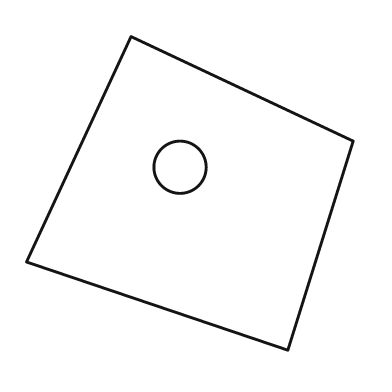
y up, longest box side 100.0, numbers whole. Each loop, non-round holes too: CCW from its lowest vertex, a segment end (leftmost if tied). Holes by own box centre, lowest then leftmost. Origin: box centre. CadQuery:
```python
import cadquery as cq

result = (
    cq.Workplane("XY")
    .moveTo(30.0, -48.0)
    .lineTo(50.0, 16.0)
    .lineTo(-18.0, 48.0)
    .lineTo(-50.0, -21.0)
    .close()
    .moveTo(-3.0, 8.0)
    .circle(8.0)
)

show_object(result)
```